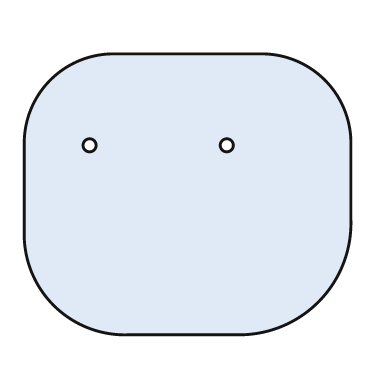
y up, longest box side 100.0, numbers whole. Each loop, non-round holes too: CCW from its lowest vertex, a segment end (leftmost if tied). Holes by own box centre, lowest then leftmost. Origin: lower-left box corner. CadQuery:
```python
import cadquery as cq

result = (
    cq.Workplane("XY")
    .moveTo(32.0, 0.0)
    .lineTo(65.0, 0.0)
    .threePointArc((90.0, 10.0), (100.0, 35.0))
    .lineTo(100.0, 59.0)
    .threePointArc((92.0, 78.0), (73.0, 86.0))
    .lineTo(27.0, 86.0)
    .threePointArc((8.0, 78.0), (0.0, 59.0))
    .lineTo(0.0, 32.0)
    .threePointArc((9.0, 9.0), (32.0, 0.0))
    .close()
    .moveTo(20.0, 58.0)
    .circle(2.0)
    .moveTo(62.0, 58.0)
    .circle(2.0)
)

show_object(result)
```